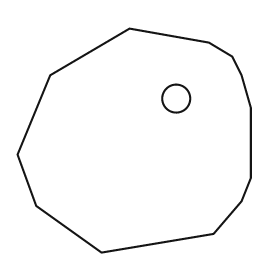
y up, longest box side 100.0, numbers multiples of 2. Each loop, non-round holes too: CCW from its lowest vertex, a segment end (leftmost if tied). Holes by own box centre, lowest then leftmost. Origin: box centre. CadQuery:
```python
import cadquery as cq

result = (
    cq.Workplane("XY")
    .moveTo(-14.0, -48.0)
    .lineTo(34.0, -40.0)
    .lineTo(46.0, -26.0)
    .lineTo(50.0, -16.0)
    .lineTo(50.0, 14.0)
    .lineTo(46.0, 28.0)
    .lineTo(42.0, 36.0)
    .lineTo(32.0, 42.0)
    .lineTo(-2.0, 48.0)
    .lineTo(-36.0, 28.0)
    .lineTo(-50.0, -6.0)
    .lineTo(-42.0, -28.0)
    .close()
    .moveTo(18.0, 18.0)
    .circle(6.0)
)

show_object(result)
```